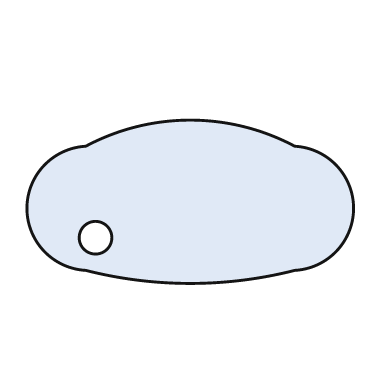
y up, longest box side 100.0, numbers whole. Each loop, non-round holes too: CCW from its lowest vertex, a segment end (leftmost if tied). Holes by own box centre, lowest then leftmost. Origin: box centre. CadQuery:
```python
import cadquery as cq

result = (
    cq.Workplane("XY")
    .moveTo(-32.0, -21.0)
    .threePointArc((0.0, -25.0), (32.0, -21.0))
    .threePointArc((50.0, -2.0), (32.0, 17.0))
    .threePointArc((0.0, 25.0), (-32.0, 17.0))
    .threePointArc((-50.0, -2.0), (-32.0, -21.0))
    .close()
    .moveTo(-29.0, -11.0)
    .circle(5.0)
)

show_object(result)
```